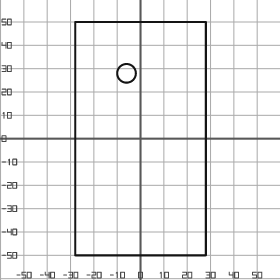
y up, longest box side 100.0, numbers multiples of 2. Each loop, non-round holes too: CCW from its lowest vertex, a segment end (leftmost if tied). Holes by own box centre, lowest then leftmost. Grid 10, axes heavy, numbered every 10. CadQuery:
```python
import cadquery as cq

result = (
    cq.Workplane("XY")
    .moveTo(-28.0, -50.0)
    .lineTo(28.0, -50.0)
    .lineTo(28.0, 50.0)
    .lineTo(-28.0, 50.0)
    .close()
    .moveTo(-6.0, 28.0)
    .circle(4.0)
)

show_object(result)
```